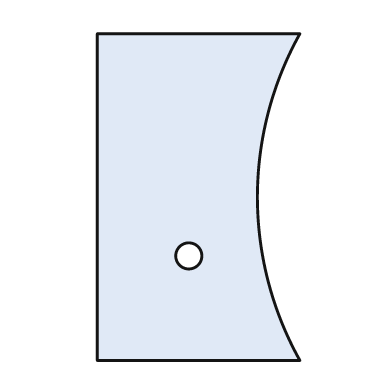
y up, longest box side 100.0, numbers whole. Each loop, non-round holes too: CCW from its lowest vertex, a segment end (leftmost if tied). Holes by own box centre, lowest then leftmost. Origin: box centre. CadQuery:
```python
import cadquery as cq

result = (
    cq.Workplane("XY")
    .moveTo(-31.0, -50.0)
    .lineTo(31.0, -50.0)
    .threePointArc((18.0, 0.0), (31.0, 50.0))
    .lineTo(-31.0, 50.0)
    .close()
    .moveTo(-3.0, -18.0)
    .circle(4.0)
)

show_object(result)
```